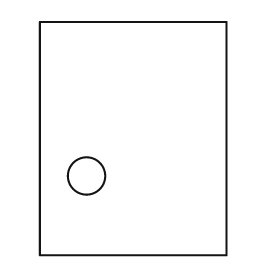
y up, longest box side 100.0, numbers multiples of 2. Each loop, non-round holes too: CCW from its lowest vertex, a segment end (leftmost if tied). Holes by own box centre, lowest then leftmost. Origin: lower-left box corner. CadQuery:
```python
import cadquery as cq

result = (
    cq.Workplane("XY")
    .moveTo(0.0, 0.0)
    .lineTo(80.0, 0.0)
    .lineTo(80.0, 100.0)
    .lineTo(0.0, 100.0)
    .close()
    .moveTo(20.0, 34.0)
    .circle(8.0)
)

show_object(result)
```